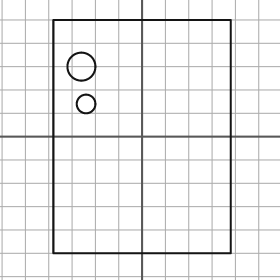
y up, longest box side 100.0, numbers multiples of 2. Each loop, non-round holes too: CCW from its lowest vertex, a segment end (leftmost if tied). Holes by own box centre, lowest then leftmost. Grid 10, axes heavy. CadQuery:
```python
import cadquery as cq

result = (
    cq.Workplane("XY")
    .moveTo(-38.0, -50.0)
    .lineTo(38.0, -50.0)
    .lineTo(38.0, 50.0)
    .lineTo(-38.0, 50.0)
    .close()
    .moveTo(-24.0, 14.0)
    .circle(4.0)
    .moveTo(-26.0, 30.0)
    .circle(6.0)
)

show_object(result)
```